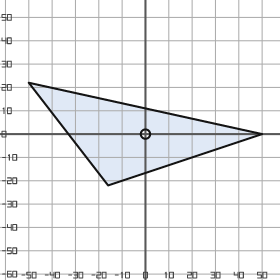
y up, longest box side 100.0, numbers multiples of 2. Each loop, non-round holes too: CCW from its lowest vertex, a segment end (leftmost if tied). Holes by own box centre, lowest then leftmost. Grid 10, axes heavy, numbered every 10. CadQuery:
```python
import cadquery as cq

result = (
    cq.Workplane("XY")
    .moveTo(-16.0, -22.0)
    .lineTo(50.0, 0.0)
    .lineTo(-50.0, 22.0)
    .close()
    .moveTo(0.0, 0.0)
    .circle(2.0)
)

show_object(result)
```